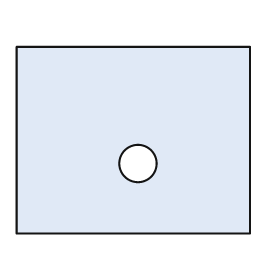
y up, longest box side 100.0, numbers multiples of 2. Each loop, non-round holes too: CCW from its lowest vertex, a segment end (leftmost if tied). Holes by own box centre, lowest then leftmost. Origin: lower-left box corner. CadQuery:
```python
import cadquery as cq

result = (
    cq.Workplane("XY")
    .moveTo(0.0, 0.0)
    .lineTo(100.0, 0.0)
    .lineTo(100.0, 80.0)
    .lineTo(0.0, 80.0)
    .close()
    .moveTo(52.0, 30.0)
    .circle(8.0)
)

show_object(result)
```